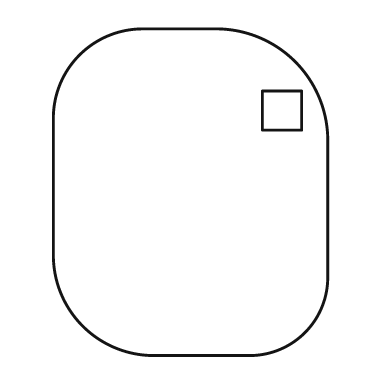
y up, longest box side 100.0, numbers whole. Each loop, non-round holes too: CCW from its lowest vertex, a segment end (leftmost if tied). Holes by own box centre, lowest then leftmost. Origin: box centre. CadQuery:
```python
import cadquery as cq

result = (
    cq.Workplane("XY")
    .moveTo(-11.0, -50.0)
    .lineTo(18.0, -50.0)
    .threePointArc((35.0, -43.0), (42.0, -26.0))
    .lineTo(42.0, 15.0)
    .threePointArc((32.0, 40.0), (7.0, 50.0))
    .lineTo(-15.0, 50.0)
    .threePointArc((-34.0, 42.0), (-42.0, 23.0))
    .lineTo(-42.0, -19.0)
    .threePointArc((-33.0, -41.0), (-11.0, -50.0))
    .close()
    .moveTo(22.0, 19.0)
    .lineTo(34.0, 19.0)
    .lineTo(34.0, 31.0)
    .lineTo(22.0, 31.0)
    .close()
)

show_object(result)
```